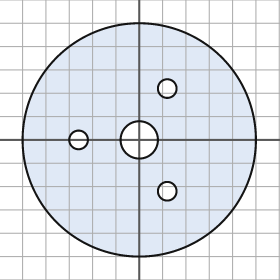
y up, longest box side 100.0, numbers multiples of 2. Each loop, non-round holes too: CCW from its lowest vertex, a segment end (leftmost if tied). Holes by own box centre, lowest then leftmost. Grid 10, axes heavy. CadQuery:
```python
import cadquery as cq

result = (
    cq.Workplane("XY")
    .moveTo(0.0, 0.0)
    .circle(50.0)
    .moveTo(12.0, -22.0)
    .circle(4.0)
    .moveTo(-26.0, 0.0)
    .circle(4.0)
    .moveTo(0.0, 0.0)
    .circle(8.0)
    .moveTo(12.0, 22.0)
    .circle(4.0)
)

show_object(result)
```